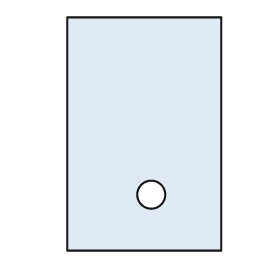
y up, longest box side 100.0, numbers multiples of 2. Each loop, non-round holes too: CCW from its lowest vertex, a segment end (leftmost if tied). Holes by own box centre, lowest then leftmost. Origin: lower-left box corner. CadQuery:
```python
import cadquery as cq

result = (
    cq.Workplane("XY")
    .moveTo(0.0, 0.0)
    .lineTo(66.0, 0.0)
    .lineTo(66.0, 100.0)
    .lineTo(0.0, 100.0)
    .close()
    .moveTo(36.0, 24.0)
    .circle(6.0)
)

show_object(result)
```